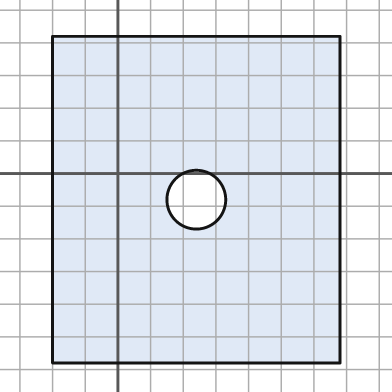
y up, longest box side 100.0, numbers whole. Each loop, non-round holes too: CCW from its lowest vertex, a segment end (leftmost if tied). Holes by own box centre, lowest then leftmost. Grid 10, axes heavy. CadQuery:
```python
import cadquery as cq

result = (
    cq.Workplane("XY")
    .moveTo(-20.0, -58.0)
    .lineTo(68.0, -58.0)
    .lineTo(68.0, 42.0)
    .lineTo(-20.0, 42.0)
    .close()
    .moveTo(24.0, -8.0)
    .circle(9.0)
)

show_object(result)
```